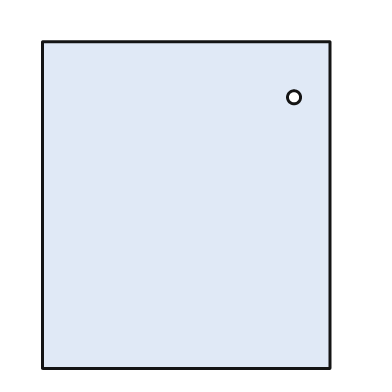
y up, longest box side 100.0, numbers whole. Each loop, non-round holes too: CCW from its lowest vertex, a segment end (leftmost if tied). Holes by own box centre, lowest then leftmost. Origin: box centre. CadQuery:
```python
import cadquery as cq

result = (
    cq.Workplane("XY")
    .moveTo(-44.0, -50.0)
    .lineTo(44.0, -50.0)
    .lineTo(44.0, 50.0)
    .lineTo(-44.0, 50.0)
    .close()
    .moveTo(33.0, 33.0)
    .circle(2.0)
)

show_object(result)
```